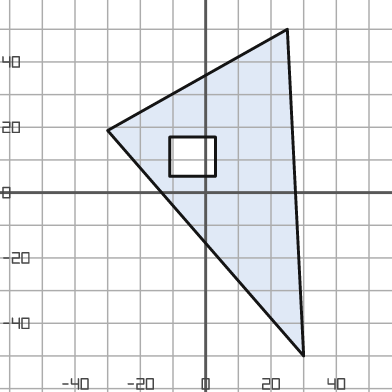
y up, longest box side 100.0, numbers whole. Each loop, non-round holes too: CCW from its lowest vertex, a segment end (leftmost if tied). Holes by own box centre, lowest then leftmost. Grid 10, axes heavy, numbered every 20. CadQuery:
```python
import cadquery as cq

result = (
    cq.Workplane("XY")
    .moveTo(30.0, -50.0)
    .lineTo(25.0, 50.0)
    .lineTo(-30.0, 19.0)
    .close()
    .moveTo(-11.0, 5.0)
    .lineTo(3.0, 5.0)
    .lineTo(3.0, 17.0)
    .lineTo(-11.0, 17.0)
    .close()
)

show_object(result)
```